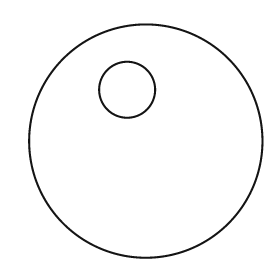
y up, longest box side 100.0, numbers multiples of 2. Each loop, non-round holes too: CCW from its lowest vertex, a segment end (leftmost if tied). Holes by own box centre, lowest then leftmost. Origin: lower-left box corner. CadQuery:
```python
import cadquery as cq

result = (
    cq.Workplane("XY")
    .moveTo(50.0, 50.0)
    .circle(50.0)
    .moveTo(42.0, 72.0)
    .circle(12.0)
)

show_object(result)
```